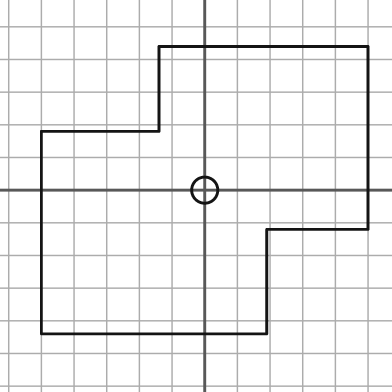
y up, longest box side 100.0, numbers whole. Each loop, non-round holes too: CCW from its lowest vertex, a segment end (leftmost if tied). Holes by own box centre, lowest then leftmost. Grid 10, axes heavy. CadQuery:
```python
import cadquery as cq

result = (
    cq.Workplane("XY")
    .moveTo(-50.0, -44.0)
    .lineTo(19.0, -44.0)
    .lineTo(19.0, -12.0)
    .lineTo(50.0, -12.0)
    .lineTo(50.0, 44.0)
    .lineTo(-14.0, 44.0)
    .lineTo(-14.0, 18.0)
    .lineTo(-50.0, 18.0)
    .close()
    .moveTo(0.0, 0.0)
    .circle(4.0)
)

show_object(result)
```